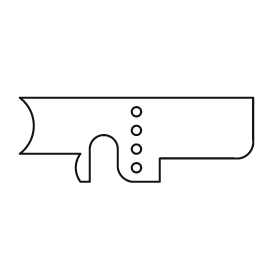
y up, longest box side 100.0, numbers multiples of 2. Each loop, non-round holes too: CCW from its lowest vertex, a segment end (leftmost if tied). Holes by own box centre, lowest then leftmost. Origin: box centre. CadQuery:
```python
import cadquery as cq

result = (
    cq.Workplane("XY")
    .moveTo(-24.0, -18.0)
    .lineTo(-20.0, -18.0)
    .lineTo(-20.0, -4.0)
    .threePointArc((-14.0, 2.0), (-8.0, -4.0))
    .lineTo(-8.0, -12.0)
    .threePointArc((-6.0, -16.0), (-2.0, -18.0))
    .lineTo(10.0, -18.0)
    .lineTo(10.0, -8.0)
    .lineTo(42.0, -8.0)
    .threePointArc((48.0, -6.0), (50.0, 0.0))
    .lineTo(50.0, 18.0)
    .lineTo(-50.0, 18.0)
    .threePointArc((-44.0, 6.0), (-50.0, -6.0))
    .lineTo(-24.0, -6.0)
    .threePointArc((-26.0, -12.0), (-24.0, -18.0))
    .close()
    .moveTo(0.0, -12.0)
    .circle(2.0)
    .moveTo(0.0, -4.0)
    .circle(2.0)
    .moveTo(0.0, 4.0)
    .circle(2.0)
    .moveTo(0.0, 12.0)
    .circle(2.0)
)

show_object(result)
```